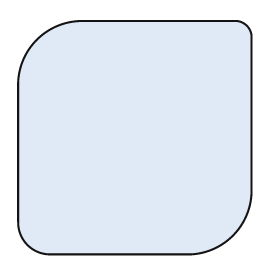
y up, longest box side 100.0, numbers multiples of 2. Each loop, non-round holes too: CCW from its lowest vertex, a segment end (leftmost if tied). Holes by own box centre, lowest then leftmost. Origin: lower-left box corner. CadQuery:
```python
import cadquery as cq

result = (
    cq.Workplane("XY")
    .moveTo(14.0, 0.0)
    .lineTo(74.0, 0.0)
    .threePointArc((92.0, 8.0), (100.0, 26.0))
    .lineTo(100.0, 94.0)
    .threePointArc((98.0, 98.0), (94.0, 100.0))
    .lineTo(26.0, 100.0)
    .threePointArc((8.0, 92.0), (0.0, 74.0))
    .lineTo(0.0, 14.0)
    .threePointArc((4.0, 4.0), (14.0, 0.0))
    .close()
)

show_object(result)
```